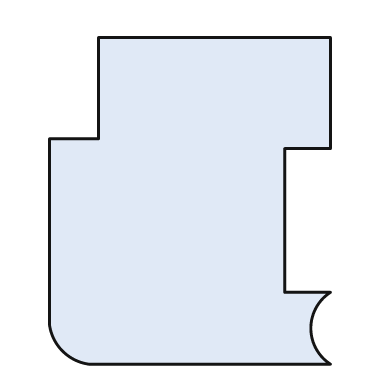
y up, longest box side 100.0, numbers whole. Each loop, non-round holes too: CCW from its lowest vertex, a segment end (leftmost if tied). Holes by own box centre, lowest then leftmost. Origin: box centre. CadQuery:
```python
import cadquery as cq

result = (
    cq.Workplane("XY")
    .moveTo(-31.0, -50.0)
    .lineTo(43.0, -50.0)
    .threePointArc((37.0, -39.0), (43.0, -28.0))
    .lineTo(29.0, -28.0)
    .lineTo(29.0, 16.0)
    .lineTo(43.0, 16.0)
    .lineTo(43.0, 50.0)
    .lineTo(-28.0, 50.0)
    .lineTo(-28.0, 19.0)
    .lineTo(-43.0, 19.0)
    .lineTo(-43.0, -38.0)
    .threePointArc((-39.0, -46.0), (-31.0, -50.0))
    .close()
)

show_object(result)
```